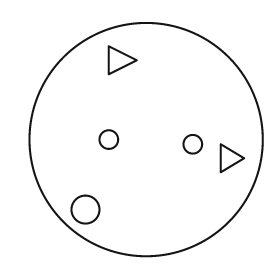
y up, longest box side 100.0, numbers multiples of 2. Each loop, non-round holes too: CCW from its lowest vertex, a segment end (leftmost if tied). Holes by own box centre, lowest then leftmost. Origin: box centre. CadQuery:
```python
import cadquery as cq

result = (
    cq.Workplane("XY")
    .moveTo(0.0, 0.0)
    .circle(50.0)
    .moveTo(-26.0, -30.0)
    .circle(6.0)
    .moveTo(32.0, -14.0)
    .lineTo(42.0, -8.0)
    .lineTo(32.0, -2.0)
    .close()
    .moveTo(20.0, -2.0)
    .circle(4.0)
    .moveTo(-16.0, 0.0)
    .circle(4.0)
    .moveTo(-16.0, 28.0)
    .lineTo(-4.0, 34.0)
    .lineTo(-16.0, 40.0)
    .close()
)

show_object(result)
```